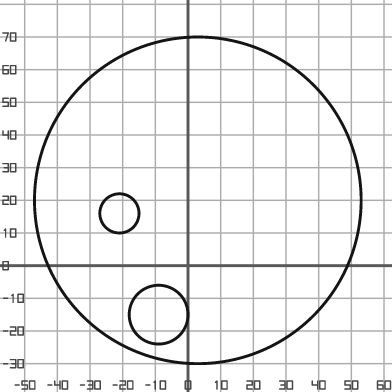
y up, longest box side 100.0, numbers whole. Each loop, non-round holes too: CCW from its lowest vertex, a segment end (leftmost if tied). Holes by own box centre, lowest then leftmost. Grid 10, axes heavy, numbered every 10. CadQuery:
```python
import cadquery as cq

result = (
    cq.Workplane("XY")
    .moveTo(3.0, 20.0)
    .circle(50.0)
    .moveTo(-9.0, -15.0)
    .circle(9.0)
    .moveTo(-21.0, 16.0)
    .circle(6.0)
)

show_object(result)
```